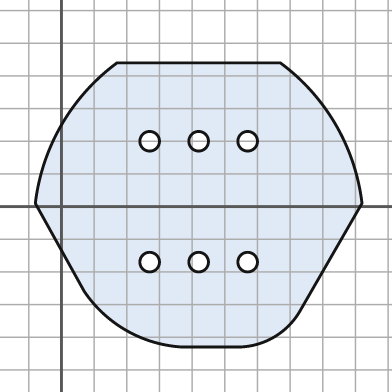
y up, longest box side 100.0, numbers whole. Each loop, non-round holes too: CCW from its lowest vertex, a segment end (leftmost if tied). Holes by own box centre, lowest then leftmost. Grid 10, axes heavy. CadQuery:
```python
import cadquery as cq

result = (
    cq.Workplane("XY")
    .moveTo(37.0, -43.0)
    .lineTo(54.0, -43.0)
    .threePointArc((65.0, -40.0), (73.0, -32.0))
    .lineTo(92.0, 1.0)
    .threePointArc((84.0, 25.0), (67.0, 44.0))
    .lineTo(17.0, 44.0)
    .threePointArc((0.0, 25.0), (-8.0, 1.0))
    .lineTo(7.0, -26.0)
    .threePointArc((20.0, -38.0), (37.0, -43.0))
    .close()
    .moveTo(27.0, -17.0)
    .circle(3.0)
    .moveTo(42.0, -17.0)
    .circle(3.0)
    .moveTo(57.0, -17.0)
    .circle(3.0)
    .moveTo(27.0, 20.0)
    .circle(3.0)
    .moveTo(42.0, 20.0)
    .circle(3.0)
    .moveTo(57.0, 20.0)
    .circle(3.0)
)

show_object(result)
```